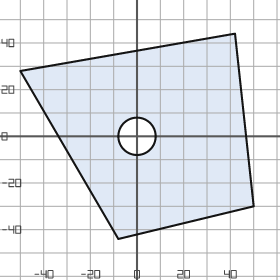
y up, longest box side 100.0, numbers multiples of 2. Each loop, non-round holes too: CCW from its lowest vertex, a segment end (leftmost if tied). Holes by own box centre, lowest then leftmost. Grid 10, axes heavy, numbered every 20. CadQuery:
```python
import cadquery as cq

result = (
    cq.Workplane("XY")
    .moveTo(-8.0, -44.0)
    .lineTo(50.0, -30.0)
    .lineTo(42.0, 44.0)
    .lineTo(-50.0, 28.0)
    .close()
    .moveTo(0.0, 0.0)
    .circle(8.0)
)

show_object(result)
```